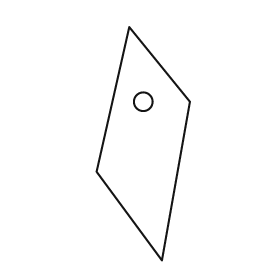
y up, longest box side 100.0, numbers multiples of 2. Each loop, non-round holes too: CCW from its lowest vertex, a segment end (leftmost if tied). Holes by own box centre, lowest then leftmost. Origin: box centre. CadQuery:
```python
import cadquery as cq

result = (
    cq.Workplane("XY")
    .moveTo(8.0, -50.0)
    .lineTo(20.0, 18.0)
    .lineTo(-6.0, 50.0)
    .lineTo(-20.0, -12.0)
    .close()
    .moveTo(0.0, 18.0)
    .circle(4.0)
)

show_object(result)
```